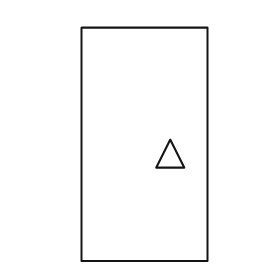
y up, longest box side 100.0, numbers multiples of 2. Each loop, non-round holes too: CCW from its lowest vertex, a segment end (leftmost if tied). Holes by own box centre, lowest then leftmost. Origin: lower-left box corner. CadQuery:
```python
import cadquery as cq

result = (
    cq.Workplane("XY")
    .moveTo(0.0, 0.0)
    .lineTo(54.0, 0.0)
    .lineTo(54.0, 100.0)
    .lineTo(0.0, 100.0)
    .close()
    .moveTo(32.0, 40.0)
    .lineTo(44.0, 40.0)
    .lineTo(38.0, 52.0)
    .close()
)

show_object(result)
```